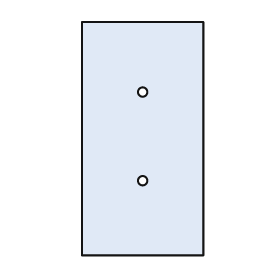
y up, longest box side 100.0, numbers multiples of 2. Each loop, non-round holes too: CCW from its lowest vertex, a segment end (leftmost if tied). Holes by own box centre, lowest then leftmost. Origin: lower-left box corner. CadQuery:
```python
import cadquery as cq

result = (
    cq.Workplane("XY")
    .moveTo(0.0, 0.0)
    .lineTo(52.0, 0.0)
    .lineTo(52.0, 100.0)
    .lineTo(0.0, 100.0)
    .close()
    .moveTo(26.0, 32.0)
    .circle(2.0)
    .moveTo(26.0, 70.0)
    .circle(2.0)
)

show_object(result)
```